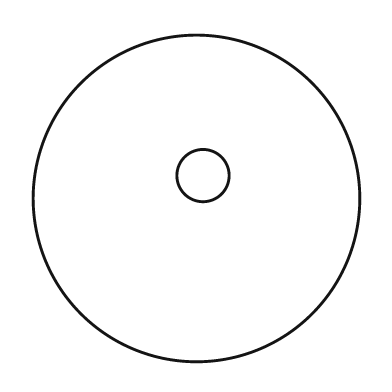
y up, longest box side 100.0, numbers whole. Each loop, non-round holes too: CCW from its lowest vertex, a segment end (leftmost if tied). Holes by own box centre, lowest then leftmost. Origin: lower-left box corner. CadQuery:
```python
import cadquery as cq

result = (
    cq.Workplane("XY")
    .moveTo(50.0, 50.0)
    .circle(50.0)
    .moveTo(52.0, 57.0)
    .circle(8.0)
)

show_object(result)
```